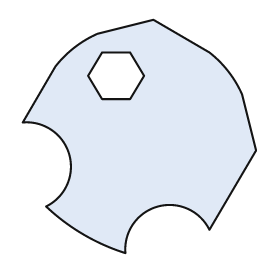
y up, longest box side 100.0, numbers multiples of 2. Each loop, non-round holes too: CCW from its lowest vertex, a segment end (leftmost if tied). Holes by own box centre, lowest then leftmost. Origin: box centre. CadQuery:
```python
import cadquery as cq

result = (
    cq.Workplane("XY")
    .moveTo(-6.0, -50.0)
    .threePointArc((8.0, -30.0), (30.0, -40.0))
    .lineTo(50.0, -6.0)
    .lineTo(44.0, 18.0)
    .threePointArc((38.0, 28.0), (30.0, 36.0))
    .lineTo(6.0, 50.0)
    .lineTo(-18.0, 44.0)
    .threePointArc((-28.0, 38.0), (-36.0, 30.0))
    .lineTo(-50.0, 6.0)
    .threePointArc((-30.0, -8.0), (-40.0, -30.0))
    .threePointArc((-24.0, -42.0), (-6.0, -50.0))
    .close()
    .moveTo(-16.0, 16.0)
    .lineTo(-4.0, 16.0)
    .lineTo(2.0, 26.0)
    .lineTo(-4.0, 36.0)
    .lineTo(-16.0, 36.0)
    .lineTo(-22.0, 26.0)
    .close()
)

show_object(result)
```